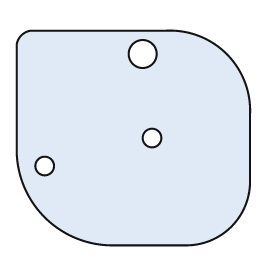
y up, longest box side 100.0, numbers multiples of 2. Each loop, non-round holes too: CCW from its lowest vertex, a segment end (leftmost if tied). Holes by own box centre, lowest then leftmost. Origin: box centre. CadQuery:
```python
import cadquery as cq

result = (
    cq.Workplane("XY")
    .moveTo(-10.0, -46.0)
    .lineTo(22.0, -46.0)
    .threePointArc((42.0, -38.0), (50.0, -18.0))
    .lineTo(50.0, 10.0)
    .threePointArc((40.0, 36.0), (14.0, 46.0))
    .lineTo(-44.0, 46.0)
    .threePointArc((-48.0, 44.0), (-50.0, 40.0))
    .lineTo(-50.0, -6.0)
    .threePointArc((-38.0, -34.0), (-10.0, -46.0))
    .close()
    .moveTo(-38.0, -12.0)
    .circle(4.0)
    .moveTo(8.0, 0.0)
    .circle(4.0)
    .moveTo(4.0, 36.0)
    .circle(6.0)
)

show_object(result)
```